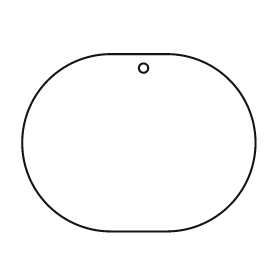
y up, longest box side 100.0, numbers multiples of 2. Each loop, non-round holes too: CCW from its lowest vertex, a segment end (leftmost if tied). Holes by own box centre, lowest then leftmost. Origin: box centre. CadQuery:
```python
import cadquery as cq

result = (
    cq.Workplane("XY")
    .moveTo(-12.0, -38.0)
    .lineTo(12.0, -38.0)
    .threePointArc((50.0, 0.0), (12.0, 38.0))
    .lineTo(-12.0, 38.0)
    .threePointArc((-50.0, 0.0), (-12.0, -38.0))
    .close()
    .moveTo(2.0, 32.0)
    .circle(2.0)
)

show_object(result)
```